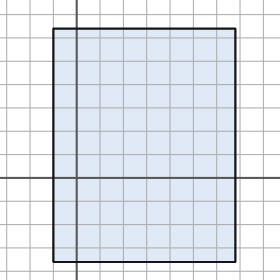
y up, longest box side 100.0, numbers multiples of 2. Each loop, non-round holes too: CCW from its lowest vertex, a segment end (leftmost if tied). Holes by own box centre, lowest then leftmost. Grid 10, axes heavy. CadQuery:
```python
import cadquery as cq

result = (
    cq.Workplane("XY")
    .moveTo(-10.0, -36.0)
    .lineTo(68.0, -36.0)
    .lineTo(68.0, 64.0)
    .lineTo(-10.0, 64.0)
    .close()
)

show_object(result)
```